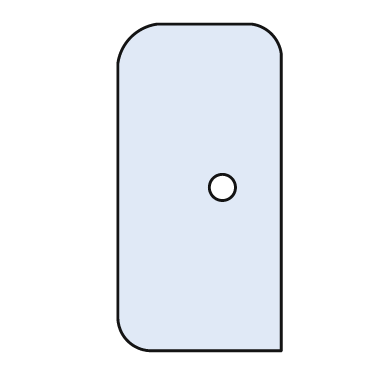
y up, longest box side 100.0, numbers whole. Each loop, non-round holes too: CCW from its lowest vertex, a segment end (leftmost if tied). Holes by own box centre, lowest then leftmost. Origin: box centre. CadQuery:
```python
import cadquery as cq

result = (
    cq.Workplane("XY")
    .moveTo(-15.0, -50.0)
    .lineTo(25.0, -50.0)
    .lineTo(25.0, 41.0)
    .threePointArc((22.0, 47.0), (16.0, 50.0))
    .lineTo(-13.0, 50.0)
    .threePointArc((-21.0, 46.0), (-25.0, 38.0))
    .lineTo(-25.0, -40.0)
    .threePointArc((-22.0, -47.0), (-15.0, -50.0))
    .close()
    .moveTo(7.0, 0.0)
    .circle(4.0)
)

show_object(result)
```